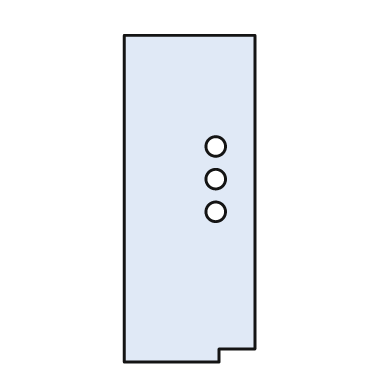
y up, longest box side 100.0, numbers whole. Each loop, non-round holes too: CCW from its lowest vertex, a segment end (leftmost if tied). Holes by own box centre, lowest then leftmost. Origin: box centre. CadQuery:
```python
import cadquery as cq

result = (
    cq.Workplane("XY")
    .moveTo(-20.0, -50.0)
    .lineTo(9.0, -50.0)
    .lineTo(9.0, -46.0)
    .lineTo(20.0, -46.0)
    .lineTo(20.0, 50.0)
    .lineTo(-20.0, 50.0)
    .close()
    .moveTo(8.0, -4.0)
    .circle(3.0)
    .moveTo(8.0, 6.0)
    .circle(3.0)
    .moveTo(8.0, 16.0)
    .circle(3.0)
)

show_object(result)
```